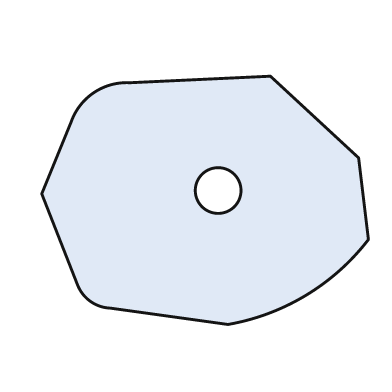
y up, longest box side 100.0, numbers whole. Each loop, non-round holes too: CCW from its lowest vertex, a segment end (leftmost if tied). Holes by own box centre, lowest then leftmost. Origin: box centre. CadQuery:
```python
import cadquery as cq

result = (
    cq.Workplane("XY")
    .moveTo(7.0, -38.0)
    .threePointArc((31.0, -29.0), (50.0, -12.0))
    .lineTo(47.0, 13.0)
    .lineTo(20.0, 38.0)
    .lineTo(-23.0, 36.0)
    .threePointArc((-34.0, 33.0), (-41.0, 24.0))
    .lineTo(-50.0, 2.0)
    .lineTo(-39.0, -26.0)
    .threePointArc((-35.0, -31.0), (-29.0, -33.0))
    .close()
    .moveTo(4.0, 3.0)
    .circle(7.0)
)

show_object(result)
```